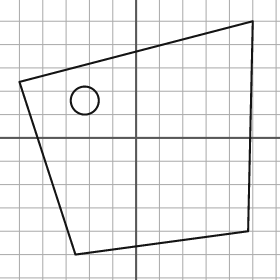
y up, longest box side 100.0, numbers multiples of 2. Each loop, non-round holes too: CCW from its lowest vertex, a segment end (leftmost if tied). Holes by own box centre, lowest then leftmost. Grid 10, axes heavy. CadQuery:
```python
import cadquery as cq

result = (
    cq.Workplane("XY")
    .moveTo(-26.0, -50.0)
    .lineTo(48.0, -40.0)
    .lineTo(50.0, 50.0)
    .lineTo(-50.0, 24.0)
    .close()
    .moveTo(-22.0, 16.0)
    .circle(6.0)
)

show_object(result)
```